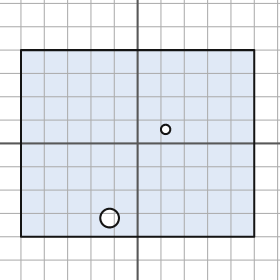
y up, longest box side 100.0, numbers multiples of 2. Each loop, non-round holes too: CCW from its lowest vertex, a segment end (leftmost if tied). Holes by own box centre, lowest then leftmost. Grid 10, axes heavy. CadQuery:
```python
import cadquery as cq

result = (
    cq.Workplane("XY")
    .moveTo(-50.0, -40.0)
    .lineTo(50.0, -40.0)
    .lineTo(50.0, 40.0)
    .lineTo(-50.0, 40.0)
    .close()
    .moveTo(-12.0, -32.0)
    .circle(4.0)
    .moveTo(12.0, 6.0)
    .circle(2.0)
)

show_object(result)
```